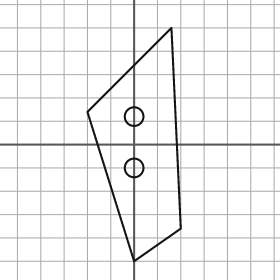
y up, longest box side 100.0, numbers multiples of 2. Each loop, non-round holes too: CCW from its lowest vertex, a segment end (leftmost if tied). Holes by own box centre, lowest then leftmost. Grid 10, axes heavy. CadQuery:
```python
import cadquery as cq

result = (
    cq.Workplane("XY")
    .moveTo(0.0, -50.0)
    .lineTo(20.0, -36.0)
    .lineTo(16.0, 50.0)
    .lineTo(-20.0, 14.0)
    .close()
    .moveTo(0.0, -10.0)
    .circle(4.0)
    .moveTo(0.0, 12.0)
    .circle(4.0)
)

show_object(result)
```